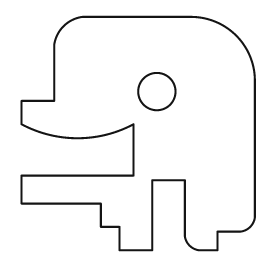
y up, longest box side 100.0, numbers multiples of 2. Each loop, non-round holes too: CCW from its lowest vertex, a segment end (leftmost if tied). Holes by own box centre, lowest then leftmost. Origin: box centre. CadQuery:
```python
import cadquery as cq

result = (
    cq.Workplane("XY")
    .moveTo(-8.0, -50.0)
    .lineTo(6.0, -50.0)
    .lineTo(6.0, -20.0)
    .lineTo(20.0, -20.0)
    .lineTo(20.0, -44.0)
    .threePointArc((22.0, -48.0), (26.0, -50.0))
    .lineTo(34.0, -50.0)
    .lineTo(34.0, -42.0)
    .lineTo(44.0, -42.0)
    .threePointArc((48.0, -40.0), (50.0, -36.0))
    .lineTo(50.0, 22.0)
    .threePointArc((42.0, 42.0), (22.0, 50.0))
    .lineTo(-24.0, 50.0)
    .threePointArc((-32.0, 46.0), (-36.0, 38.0))
    .lineTo(-36.0, 14.0)
    .lineTo(-50.0, 14.0)
    .lineTo(-50.0, 4.0)
    .threePointArc((-26.0, -2.0), (-2.0, 4.0))
    .lineTo(-2.0, -18.0)
    .lineTo(-50.0, -18.0)
    .lineTo(-50.0, -30.0)
    .lineTo(-16.0, -30.0)
    .lineTo(-16.0, -40.0)
    .lineTo(-8.0, -40.0)
    .close()
    .moveTo(8.0, 18.0)
    .circle(8.0)
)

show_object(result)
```